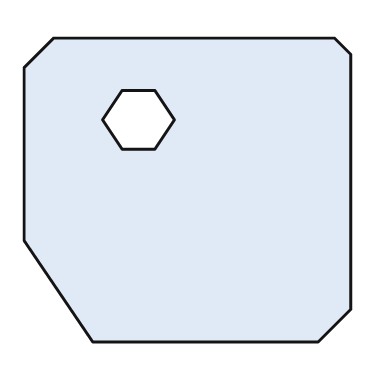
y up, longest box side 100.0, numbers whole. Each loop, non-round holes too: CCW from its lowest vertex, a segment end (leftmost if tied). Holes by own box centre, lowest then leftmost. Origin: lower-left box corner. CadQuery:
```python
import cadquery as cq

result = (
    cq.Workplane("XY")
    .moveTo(21.0, 0.0)
    .lineTo(90.0, 0.0)
    .lineTo(100.0, 10.0)
    .lineTo(100.0, 88.0)
    .lineTo(95.0, 93.0)
    .lineTo(9.0, 93.0)
    .lineTo(0.0, 84.0)
    .lineTo(0.0, 31.0)
    .close()
    .moveTo(30.0, 59.0)
    .lineTo(40.0, 59.0)
    .lineTo(46.0, 68.0)
    .lineTo(40.0, 77.0)
    .lineTo(30.0, 77.0)
    .lineTo(24.0, 68.0)
    .close()
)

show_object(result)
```